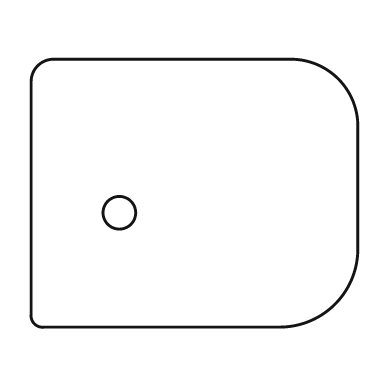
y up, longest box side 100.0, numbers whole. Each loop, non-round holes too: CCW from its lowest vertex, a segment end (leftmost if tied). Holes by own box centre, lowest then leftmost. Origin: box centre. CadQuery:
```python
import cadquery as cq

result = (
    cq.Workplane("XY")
    .moveTo(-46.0, -41.0)
    .lineTo(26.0, -41.0)
    .threePointArc((43.0, -34.0), (50.0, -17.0))
    .lineTo(50.0, 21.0)
    .threePointArc((44.0, 35.0), (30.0, 41.0))
    .lineTo(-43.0, 41.0)
    .threePointArc((-48.0, 39.0), (-50.0, 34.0))
    .lineTo(-50.0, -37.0)
    .threePointArc((-49.0, -40.0), (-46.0, -41.0))
    .close()
    .moveTo(-23.0, -6.0)
    .circle(5.0)
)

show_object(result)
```